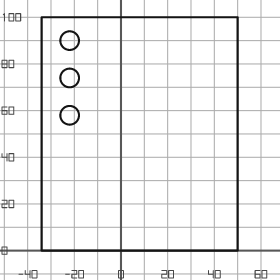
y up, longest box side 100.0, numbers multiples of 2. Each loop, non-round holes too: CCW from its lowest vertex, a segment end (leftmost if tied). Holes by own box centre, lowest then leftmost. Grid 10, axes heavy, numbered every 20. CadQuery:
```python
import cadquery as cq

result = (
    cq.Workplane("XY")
    .moveTo(-34.0, 0.0)
    .lineTo(50.0, 0.0)
    .lineTo(50.0, 100.0)
    .lineTo(-34.0, 100.0)
    .close()
    .moveTo(-22.0, 58.0)
    .circle(4.0)
    .moveTo(-22.0, 74.0)
    .circle(4.0)
    .moveTo(-22.0, 90.0)
    .circle(4.0)
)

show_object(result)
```